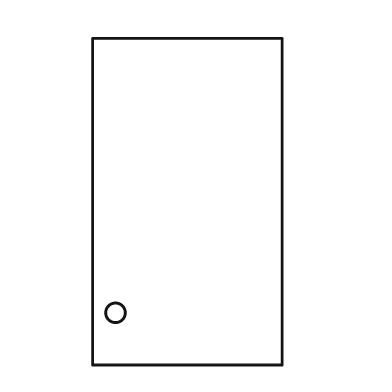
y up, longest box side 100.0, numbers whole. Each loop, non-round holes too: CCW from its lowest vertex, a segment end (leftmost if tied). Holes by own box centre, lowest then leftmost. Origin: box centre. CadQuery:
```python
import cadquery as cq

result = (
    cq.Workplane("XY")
    .moveTo(-29.0, -50.0)
    .lineTo(29.0, -50.0)
    .lineTo(29.0, 50.0)
    .lineTo(-29.0, 50.0)
    .close()
    .moveTo(-22.0, -34.0)
    .circle(3.0)
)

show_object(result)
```